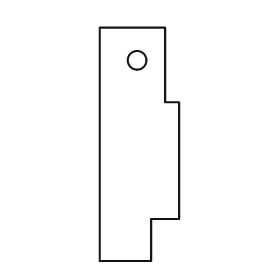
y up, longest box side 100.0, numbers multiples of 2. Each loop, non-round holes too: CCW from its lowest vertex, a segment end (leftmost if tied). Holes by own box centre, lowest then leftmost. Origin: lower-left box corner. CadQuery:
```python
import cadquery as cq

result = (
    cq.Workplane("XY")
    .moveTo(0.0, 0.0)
    .lineTo(22.0, 0.0)
    .lineTo(22.0, 18.0)
    .lineTo(34.0, 18.0)
    .lineTo(34.0, 68.0)
    .lineTo(28.0, 68.0)
    .lineTo(28.0, 100.0)
    .lineTo(0.0, 100.0)
    .close()
    .moveTo(16.0, 86.0)
    .circle(4.0)
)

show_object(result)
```